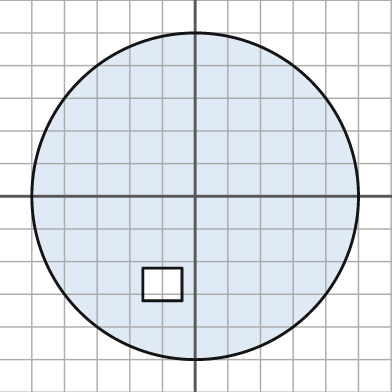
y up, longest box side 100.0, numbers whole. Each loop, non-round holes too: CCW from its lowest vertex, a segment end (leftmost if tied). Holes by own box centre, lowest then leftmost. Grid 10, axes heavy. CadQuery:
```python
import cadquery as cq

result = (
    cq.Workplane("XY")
    .moveTo(0.0, 0.0)
    .circle(50.0)
    .moveTo(-16.0, -32.0)
    .lineTo(-4.0, -32.0)
    .lineTo(-4.0, -22.0)
    .lineTo(-16.0, -22.0)
    .close()
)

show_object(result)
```